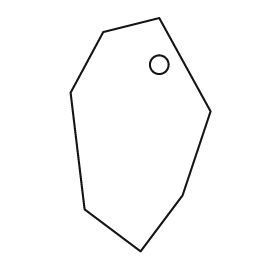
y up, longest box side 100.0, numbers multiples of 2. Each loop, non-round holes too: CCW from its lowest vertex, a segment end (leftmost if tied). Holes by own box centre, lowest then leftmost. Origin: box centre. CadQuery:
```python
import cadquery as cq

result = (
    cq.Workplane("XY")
    .moveTo(0.0, -50.0)
    .lineTo(18.0, -26.0)
    .lineTo(30.0, 10.0)
    .lineTo(8.0, 50.0)
    .lineTo(-16.0, 44.0)
    .lineTo(-30.0, 18.0)
    .lineTo(-24.0, -32.0)
    .close()
    .moveTo(8.0, 30.0)
    .circle(4.0)
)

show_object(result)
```